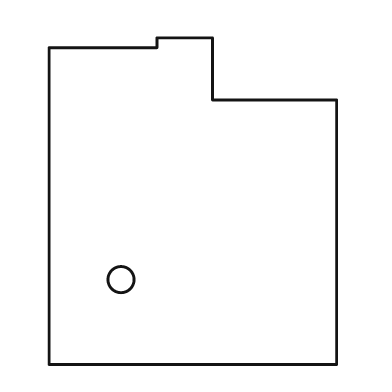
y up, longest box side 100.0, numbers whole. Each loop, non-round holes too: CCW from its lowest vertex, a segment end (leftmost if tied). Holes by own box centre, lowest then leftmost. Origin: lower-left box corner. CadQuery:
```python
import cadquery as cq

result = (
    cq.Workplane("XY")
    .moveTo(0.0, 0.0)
    .lineTo(88.0, 0.0)
    .lineTo(88.0, 81.0)
    .lineTo(50.0, 81.0)
    .lineTo(50.0, 100.0)
    .lineTo(33.0, 100.0)
    .lineTo(33.0, 97.0)
    .lineTo(0.0, 97.0)
    .close()
    .moveTo(22.0, 26.0)
    .circle(4.0)
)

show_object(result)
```